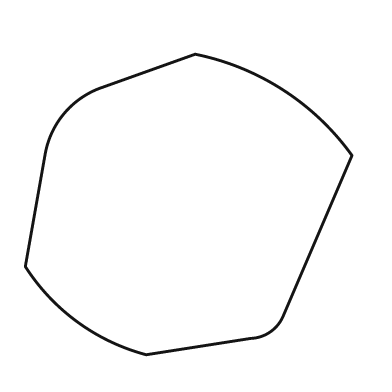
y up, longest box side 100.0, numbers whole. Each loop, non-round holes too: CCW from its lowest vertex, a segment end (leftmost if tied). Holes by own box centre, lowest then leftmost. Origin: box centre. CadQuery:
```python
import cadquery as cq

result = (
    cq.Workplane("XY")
    .moveTo(-13.0, -46.0)
    .lineTo(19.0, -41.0)
    .threePointArc((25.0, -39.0), (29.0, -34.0))
    .lineTo(50.0, 15.0)
    .threePointArc((29.0, 35.0), (2.0, 46.0))
    .lineTo(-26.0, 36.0)
    .threePointArc((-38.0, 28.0), (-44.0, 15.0))
    .lineTo(-50.0, -19.0)
    .threePointArc((-34.0, -36.0), (-13.0, -46.0))
    .close()
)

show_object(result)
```